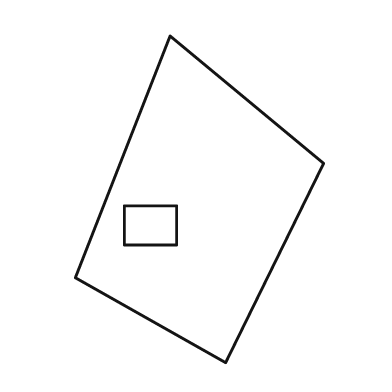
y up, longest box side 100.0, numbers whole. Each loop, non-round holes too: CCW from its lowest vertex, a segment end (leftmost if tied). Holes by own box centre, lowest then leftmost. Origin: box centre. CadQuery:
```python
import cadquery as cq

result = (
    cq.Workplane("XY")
    .moveTo(8.0, -50.0)
    .lineTo(38.0, 11.0)
    .lineTo(-9.0, 50.0)
    .lineTo(-38.0, -24.0)
    .close()
    .moveTo(-23.0, -14.0)
    .lineTo(-7.0, -14.0)
    .lineTo(-7.0, -2.0)
    .lineTo(-23.0, -2.0)
    .close()
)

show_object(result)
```